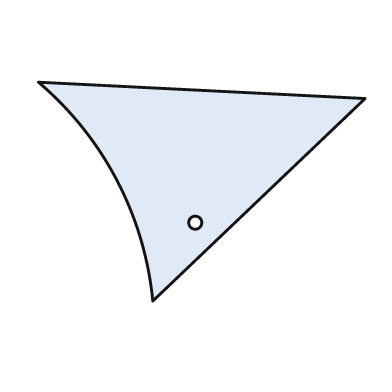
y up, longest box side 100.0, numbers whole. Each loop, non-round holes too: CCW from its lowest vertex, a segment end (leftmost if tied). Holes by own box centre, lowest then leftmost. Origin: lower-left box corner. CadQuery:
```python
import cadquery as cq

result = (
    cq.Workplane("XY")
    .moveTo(35.0, 0.0)
    .lineTo(100.0, 62.0)
    .lineTo(0.0, 67.0)
    .threePointArc((24.0, 37.0), (35.0, 0.0))
    .close()
    .moveTo(48.0, 24.0)
    .circle(2.0)
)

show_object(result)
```